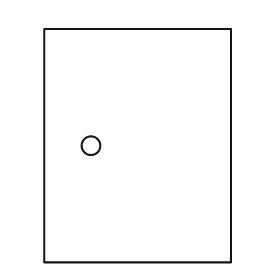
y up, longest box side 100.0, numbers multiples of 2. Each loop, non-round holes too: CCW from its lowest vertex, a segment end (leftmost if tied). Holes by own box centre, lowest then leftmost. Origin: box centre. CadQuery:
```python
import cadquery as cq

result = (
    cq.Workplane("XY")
    .moveTo(-40.0, -50.0)
    .lineTo(40.0, -50.0)
    .lineTo(40.0, 50.0)
    .lineTo(-40.0, 50.0)
    .close()
    .moveTo(-20.0, 0.0)
    .circle(4.0)
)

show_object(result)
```